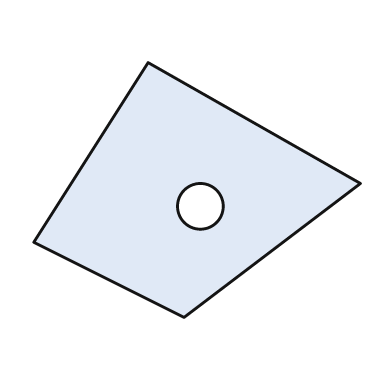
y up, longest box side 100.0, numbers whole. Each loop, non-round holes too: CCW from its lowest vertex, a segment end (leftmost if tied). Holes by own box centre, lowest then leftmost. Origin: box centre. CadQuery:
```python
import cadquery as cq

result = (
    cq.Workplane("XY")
    .moveTo(-4.0, -39.0)
    .lineTo(50.0, 2.0)
    .lineTo(-15.0, 39.0)
    .lineTo(-50.0, -16.0)
    .close()
    .moveTo(1.0, -5.0)
    .circle(7.0)
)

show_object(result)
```